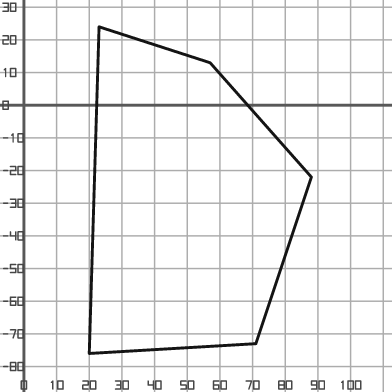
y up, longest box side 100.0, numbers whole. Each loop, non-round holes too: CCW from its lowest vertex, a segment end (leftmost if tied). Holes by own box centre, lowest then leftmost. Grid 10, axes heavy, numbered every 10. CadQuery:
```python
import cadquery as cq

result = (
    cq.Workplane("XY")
    .moveTo(20.0, -76.0)
    .lineTo(71.0, -73.0)
    .lineTo(88.0, -22.0)
    .lineTo(57.0, 13.0)
    .lineTo(23.0, 24.0)
    .close()
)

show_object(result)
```